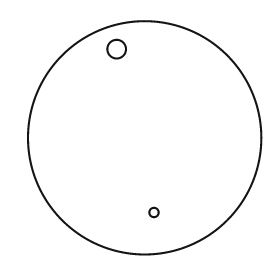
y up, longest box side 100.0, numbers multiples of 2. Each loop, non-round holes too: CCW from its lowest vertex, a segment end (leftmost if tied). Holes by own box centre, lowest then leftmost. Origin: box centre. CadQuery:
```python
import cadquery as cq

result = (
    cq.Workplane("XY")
    .moveTo(0.0, 0.0)
    .circle(50.0)
    .moveTo(4.0, -32.0)
    .circle(2.0)
    .moveTo(-12.0, 38.0)
    .circle(4.0)
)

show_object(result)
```